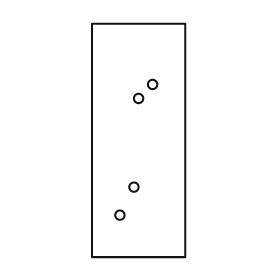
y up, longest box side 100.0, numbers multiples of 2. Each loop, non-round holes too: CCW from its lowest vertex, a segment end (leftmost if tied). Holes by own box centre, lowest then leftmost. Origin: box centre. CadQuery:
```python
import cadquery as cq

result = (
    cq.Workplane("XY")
    .moveTo(-20.0, -50.0)
    .lineTo(20.0, -50.0)
    .lineTo(20.0, 50.0)
    .lineTo(-20.0, 50.0)
    .close()
    .moveTo(-8.0, -32.0)
    .circle(2.0)
    .moveTo(-2.0, -20.0)
    .circle(2.0)
    .moveTo(0.0, 18.0)
    .circle(2.0)
    .moveTo(6.0, 24.0)
    .circle(2.0)
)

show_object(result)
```